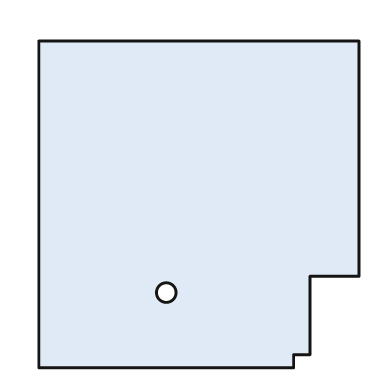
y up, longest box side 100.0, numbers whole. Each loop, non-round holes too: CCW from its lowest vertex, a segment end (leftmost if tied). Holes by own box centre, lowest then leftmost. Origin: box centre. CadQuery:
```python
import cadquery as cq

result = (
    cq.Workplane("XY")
    .moveTo(-49.0, -50.0)
    .lineTo(29.0, -50.0)
    .lineTo(29.0, -46.0)
    .lineTo(34.0, -46.0)
    .lineTo(34.0, -22.0)
    .lineTo(49.0, -22.0)
    .lineTo(49.0, 50.0)
    .lineTo(-49.0, 50.0)
    .close()
    .moveTo(-10.0, -27.0)
    .circle(3.0)
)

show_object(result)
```